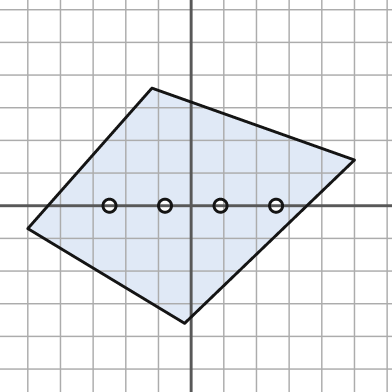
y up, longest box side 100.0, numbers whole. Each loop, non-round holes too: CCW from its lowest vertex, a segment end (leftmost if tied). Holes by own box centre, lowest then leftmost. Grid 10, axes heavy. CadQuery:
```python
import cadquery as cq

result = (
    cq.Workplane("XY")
    .moveTo(-2.0, -36.0)
    .lineTo(50.0, 14.0)
    .lineTo(-12.0, 36.0)
    .lineTo(-50.0, -7.0)
    .close()
    .moveTo(-25.0, 0.0)
    .circle(2.0)
    .moveTo(-8.0, 0.0)
    .circle(2.0)
    .moveTo(9.0, 0.0)
    .circle(2.0)
    .moveTo(26.0, 0.0)
    .circle(2.0)
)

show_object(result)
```